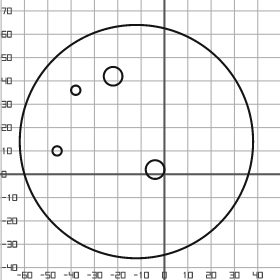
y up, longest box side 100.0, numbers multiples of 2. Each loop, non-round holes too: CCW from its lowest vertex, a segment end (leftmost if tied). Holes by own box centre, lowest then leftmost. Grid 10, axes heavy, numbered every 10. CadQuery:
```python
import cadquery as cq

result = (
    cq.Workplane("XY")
    .moveTo(-12.0, 14.0)
    .circle(50.0)
    .moveTo(-4.0, 2.0)
    .circle(4.0)
    .moveTo(-46.0, 10.0)
    .circle(2.0)
    .moveTo(-38.0, 36.0)
    .circle(2.0)
    .moveTo(-22.0, 42.0)
    .circle(4.0)
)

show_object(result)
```